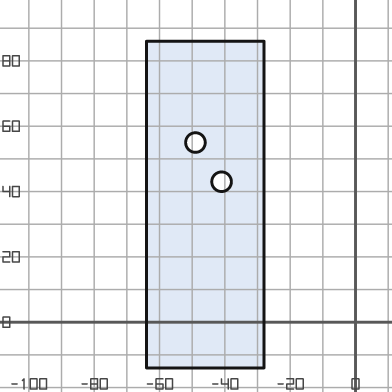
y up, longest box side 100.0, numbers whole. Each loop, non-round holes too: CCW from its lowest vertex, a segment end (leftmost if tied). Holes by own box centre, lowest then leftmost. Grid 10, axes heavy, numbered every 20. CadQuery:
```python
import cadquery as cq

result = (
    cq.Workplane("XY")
    .moveTo(-64.0, -14.0)
    .lineTo(-28.0, -14.0)
    .lineTo(-28.0, 86.0)
    .lineTo(-64.0, 86.0)
    .close()
    .moveTo(-41.0, 43.0)
    .circle(3.0)
    .moveTo(-49.0, 55.0)
    .circle(3.0)
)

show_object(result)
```